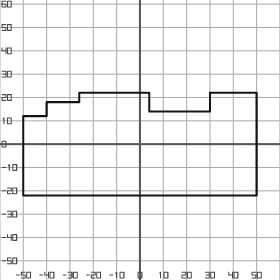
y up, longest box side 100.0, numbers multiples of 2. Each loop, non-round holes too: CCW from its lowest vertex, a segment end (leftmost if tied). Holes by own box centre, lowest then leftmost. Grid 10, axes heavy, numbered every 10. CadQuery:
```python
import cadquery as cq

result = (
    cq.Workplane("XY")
    .moveTo(-50.0, -22.0)
    .lineTo(50.0, -22.0)
    .lineTo(50.0, 22.0)
    .lineTo(30.0, 22.0)
    .lineTo(30.0, 14.0)
    .lineTo(4.0, 14.0)
    .lineTo(4.0, 22.0)
    .lineTo(-26.0, 22.0)
    .lineTo(-26.0, 18.0)
    .lineTo(-40.0, 18.0)
    .lineTo(-40.0, 12.0)
    .lineTo(-50.0, 12.0)
    .close()
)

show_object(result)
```